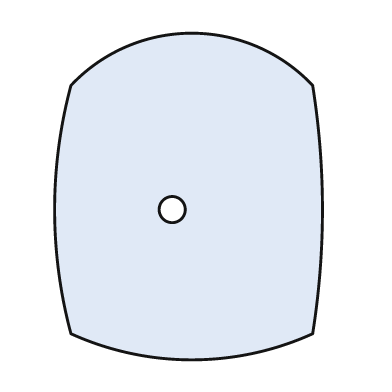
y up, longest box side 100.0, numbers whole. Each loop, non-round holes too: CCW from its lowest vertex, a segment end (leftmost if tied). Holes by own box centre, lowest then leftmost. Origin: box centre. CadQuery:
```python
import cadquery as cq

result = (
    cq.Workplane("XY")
    .moveTo(-36.0, -42.0)
    .threePointArc((1.0, -50.0), (38.0, -42.0))
    .threePointArc((41.0, -4.0), (38.0, 34.0))
    .threePointArc((1.0, 50.0), (-36.0, 34.0))
    .threePointArc((-41.0, -4.0), (-36.0, -42.0))
    .close()
    .moveTo(-5.0, -4.0)
    .circle(4.0)
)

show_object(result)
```